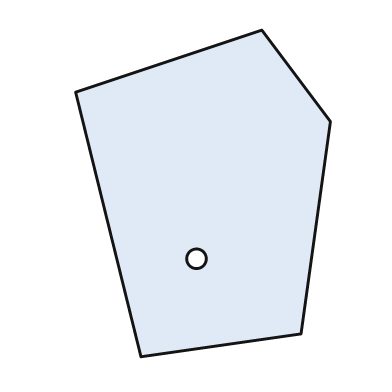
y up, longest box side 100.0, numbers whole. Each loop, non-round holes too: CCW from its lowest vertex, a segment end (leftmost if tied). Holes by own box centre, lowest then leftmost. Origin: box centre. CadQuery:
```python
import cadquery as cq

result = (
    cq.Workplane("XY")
    .moveTo(-19.0, -50.0)
    .lineTo(30.0, -43.0)
    .lineTo(39.0, 22.0)
    .lineTo(18.0, 50.0)
    .lineTo(-39.0, 31.0)
    .close()
    .moveTo(-2.0, -20.0)
    .circle(3.0)
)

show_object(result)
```